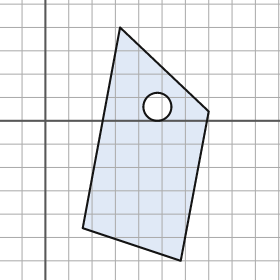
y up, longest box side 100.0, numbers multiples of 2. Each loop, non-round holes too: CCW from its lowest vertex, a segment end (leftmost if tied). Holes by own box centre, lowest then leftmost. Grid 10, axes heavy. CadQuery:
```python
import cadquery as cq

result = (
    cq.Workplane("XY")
    .moveTo(58.0, -60.0)
    .lineTo(70.0, 4.0)
    .lineTo(32.0, 40.0)
    .lineTo(16.0, -46.0)
    .close()
    .moveTo(48.0, 6.0)
    .circle(6.0)
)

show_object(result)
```